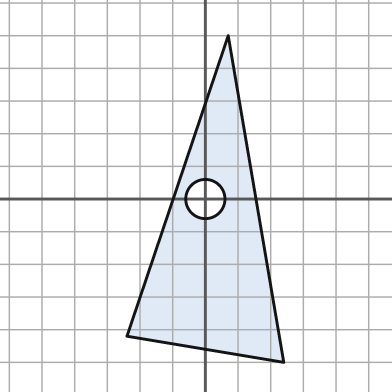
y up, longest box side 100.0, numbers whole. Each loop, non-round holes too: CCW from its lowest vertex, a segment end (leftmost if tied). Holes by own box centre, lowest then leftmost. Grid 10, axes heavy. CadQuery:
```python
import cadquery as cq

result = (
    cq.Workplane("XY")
    .moveTo(24.0, -50.0)
    .lineTo(7.0, 50.0)
    .lineTo(-24.0, -42.0)
    .close()
    .moveTo(0.0, 0.0)
    .circle(6.0)
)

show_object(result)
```